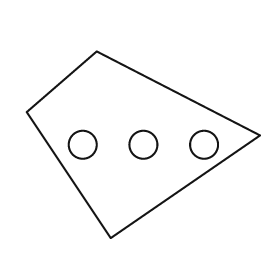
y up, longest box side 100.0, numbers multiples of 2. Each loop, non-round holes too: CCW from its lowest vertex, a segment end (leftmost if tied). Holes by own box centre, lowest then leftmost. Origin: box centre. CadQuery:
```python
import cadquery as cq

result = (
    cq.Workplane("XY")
    .moveTo(-14.0, -40.0)
    .lineTo(50.0, 4.0)
    .lineTo(-20.0, 40.0)
    .lineTo(-50.0, 14.0)
    .close()
    .moveTo(-26.0, 0.0)
    .circle(6.0)
    .moveTo(0.0, 0.0)
    .circle(6.0)
    .moveTo(26.0, 0.0)
    .circle(6.0)
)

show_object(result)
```